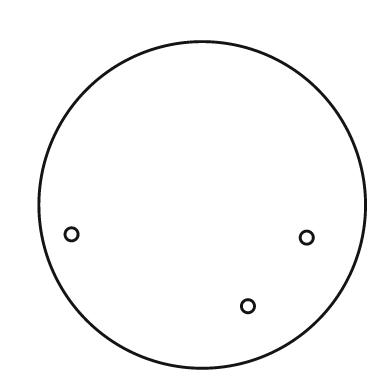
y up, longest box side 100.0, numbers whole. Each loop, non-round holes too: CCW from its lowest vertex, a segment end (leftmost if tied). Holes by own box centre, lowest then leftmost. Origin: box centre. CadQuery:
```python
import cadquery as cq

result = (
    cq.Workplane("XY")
    .moveTo(0.0, 0.0)
    .circle(50.0)
    .moveTo(14.0, -31.0)
    .circle(2.0)
    .moveTo(32.0, -10.0)
    .circle(2.0)
    .moveTo(-40.0, -9.0)
    .circle(2.0)
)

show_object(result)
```